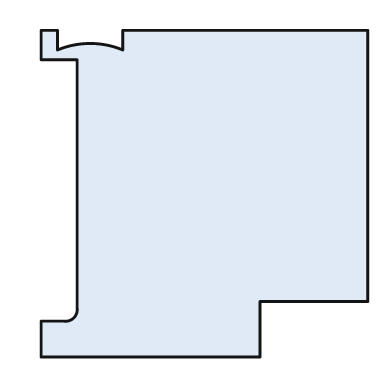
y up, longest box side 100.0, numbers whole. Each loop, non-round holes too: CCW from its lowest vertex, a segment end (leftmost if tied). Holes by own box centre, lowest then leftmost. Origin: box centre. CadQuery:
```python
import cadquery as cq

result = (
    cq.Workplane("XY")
    .moveTo(-50.0, -50.0)
    .lineTo(17.0, -50.0)
    .lineTo(17.0, -33.0)
    .lineTo(50.0, -33.0)
    .lineTo(50.0, 50.0)
    .lineTo(-25.0, 50.0)
    .lineTo(-25.0, 44.0)
    .threePointArc((-35.0, 46.0), (-45.0, 44.0))
    .lineTo(-45.0, 50.0)
    .lineTo(-50.0, 50.0)
    .lineTo(-50.0, 41.0)
    .lineTo(-39.0, 41.0)
    .lineTo(-39.0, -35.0)
    .threePointArc((-40.0, -38.0), (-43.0, -39.0))
    .lineTo(-50.0, -39.0)
    .close()
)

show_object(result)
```